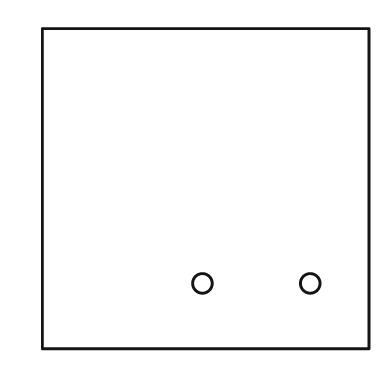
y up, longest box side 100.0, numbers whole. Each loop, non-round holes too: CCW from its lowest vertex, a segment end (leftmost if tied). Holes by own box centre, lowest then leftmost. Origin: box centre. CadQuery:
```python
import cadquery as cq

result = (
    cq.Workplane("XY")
    .moveTo(-50.0, -49.0)
    .lineTo(50.0, -49.0)
    .lineTo(50.0, 49.0)
    .lineTo(-50.0, 49.0)
    .close()
    .moveTo(-1.0, -29.0)
    .circle(3.0)
    .moveTo(32.0, -29.0)
    .circle(3.0)
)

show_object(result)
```